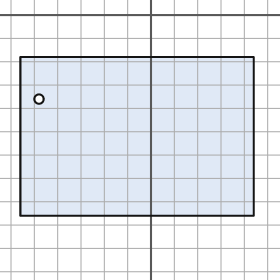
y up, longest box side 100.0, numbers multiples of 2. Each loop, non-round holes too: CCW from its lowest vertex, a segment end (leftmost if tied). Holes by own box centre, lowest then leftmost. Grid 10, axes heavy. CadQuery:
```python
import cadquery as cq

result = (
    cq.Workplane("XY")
    .moveTo(-56.0, -86.0)
    .lineTo(44.0, -86.0)
    .lineTo(44.0, -18.0)
    .lineTo(-56.0, -18.0)
    .close()
    .moveTo(-48.0, -36.0)
    .circle(2.0)
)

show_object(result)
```